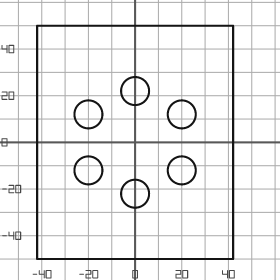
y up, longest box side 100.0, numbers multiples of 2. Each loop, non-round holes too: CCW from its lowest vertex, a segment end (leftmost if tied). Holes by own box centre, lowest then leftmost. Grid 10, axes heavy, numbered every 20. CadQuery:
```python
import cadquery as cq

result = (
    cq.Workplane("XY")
    .moveTo(-42.0, -50.0)
    .lineTo(42.0, -50.0)
    .lineTo(42.0, 50.0)
    .lineTo(-42.0, 50.0)
    .close()
    .moveTo(0.0, -22.0)
    .circle(6.0)
    .moveTo(-20.0, -12.0)
    .circle(6.0)
    .moveTo(20.0, -12.0)
    .circle(6.0)
    .moveTo(-20.0, 12.0)
    .circle(6.0)
    .moveTo(20.0, 12.0)
    .circle(6.0)
    .moveTo(0.0, 22.0)
    .circle(6.0)
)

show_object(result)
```